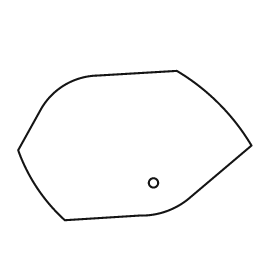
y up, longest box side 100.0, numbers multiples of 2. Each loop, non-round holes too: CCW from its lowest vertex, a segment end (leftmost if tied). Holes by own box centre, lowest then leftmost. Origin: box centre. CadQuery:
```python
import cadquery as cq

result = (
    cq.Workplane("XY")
    .moveTo(-30.0, -32.0)
    .lineTo(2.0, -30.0)
    .threePointArc((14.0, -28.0), (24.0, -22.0))
    .lineTo(50.0, 0.0)
    .threePointArc((36.0, 18.0), (18.0, 32.0))
    .lineTo(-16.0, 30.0)
    .threePointArc((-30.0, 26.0), (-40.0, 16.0))
    .lineTo(-50.0, -2.0)
    .threePointArc((-42.0, -18.0), (-30.0, -32.0))
    .close()
    .moveTo(8.0, -16.0)
    .circle(2.0)
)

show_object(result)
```